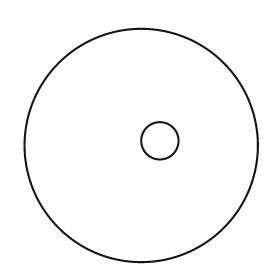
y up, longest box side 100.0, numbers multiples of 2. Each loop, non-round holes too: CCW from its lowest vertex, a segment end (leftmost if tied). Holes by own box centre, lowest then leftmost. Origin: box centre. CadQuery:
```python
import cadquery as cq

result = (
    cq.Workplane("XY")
    .moveTo(0.0, 0.0)
    .circle(50.0)
    .moveTo(8.0, 2.0)
    .circle(8.0)
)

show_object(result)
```